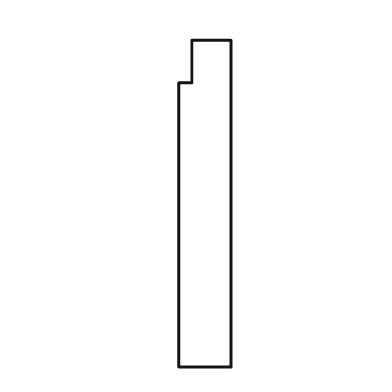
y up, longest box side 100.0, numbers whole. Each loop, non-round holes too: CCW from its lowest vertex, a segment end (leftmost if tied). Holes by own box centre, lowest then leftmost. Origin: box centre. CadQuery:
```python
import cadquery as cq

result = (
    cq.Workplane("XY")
    .moveTo(-8.0, -50.0)
    .lineTo(8.0, -50.0)
    .lineTo(8.0, 50.0)
    .lineTo(-4.0, 50.0)
    .lineTo(-4.0, 37.0)
    .lineTo(-8.0, 37.0)
    .close()
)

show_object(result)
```